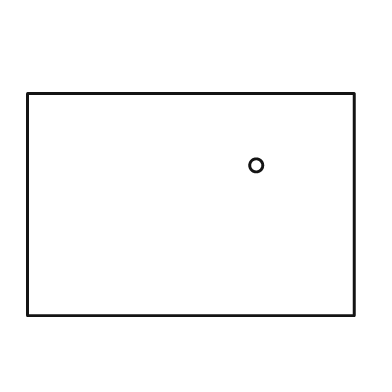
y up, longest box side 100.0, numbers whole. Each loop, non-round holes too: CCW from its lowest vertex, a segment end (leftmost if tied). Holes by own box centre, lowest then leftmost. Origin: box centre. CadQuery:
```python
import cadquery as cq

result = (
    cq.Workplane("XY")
    .moveTo(-50.0, -34.0)
    .lineTo(50.0, -34.0)
    .lineTo(50.0, 34.0)
    .lineTo(-50.0, 34.0)
    .close()
    .moveTo(20.0, 12.0)
    .circle(2.0)
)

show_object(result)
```